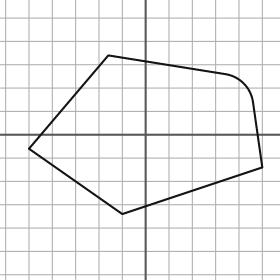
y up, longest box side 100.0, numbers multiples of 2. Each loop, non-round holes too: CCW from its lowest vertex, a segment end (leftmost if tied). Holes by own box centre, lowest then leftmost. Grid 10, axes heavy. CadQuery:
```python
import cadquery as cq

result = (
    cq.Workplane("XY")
    .moveTo(-10.0, -34.0)
    .lineTo(50.0, -14.0)
    .lineTo(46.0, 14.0)
    .threePointArc((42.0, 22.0), (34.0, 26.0))
    .lineTo(-16.0, 34.0)
    .lineTo(-50.0, -6.0)
    .close()
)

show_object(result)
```